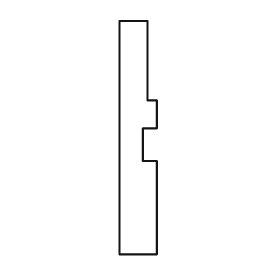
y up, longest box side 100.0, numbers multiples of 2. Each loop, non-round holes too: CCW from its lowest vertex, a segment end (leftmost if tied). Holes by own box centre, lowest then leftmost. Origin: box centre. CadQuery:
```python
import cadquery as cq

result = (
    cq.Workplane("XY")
    .moveTo(-8.0, -50.0)
    .lineTo(8.0, -50.0)
    .lineTo(8.0, -10.0)
    .lineTo(2.0, -10.0)
    .lineTo(2.0, 4.0)
    .lineTo(8.0, 4.0)
    .lineTo(8.0, 16.0)
    .lineTo(4.0, 16.0)
    .lineTo(4.0, 50.0)
    .lineTo(-8.0, 50.0)
    .close()
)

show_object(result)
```